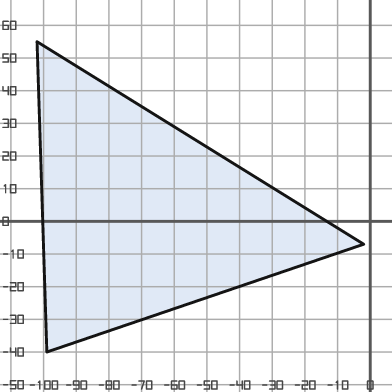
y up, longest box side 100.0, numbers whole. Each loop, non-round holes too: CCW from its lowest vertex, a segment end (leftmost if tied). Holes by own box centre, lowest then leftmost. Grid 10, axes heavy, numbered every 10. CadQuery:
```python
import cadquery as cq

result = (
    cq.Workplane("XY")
    .moveTo(-99.0, -40.0)
    .lineTo(-2.0, -7.0)
    .lineTo(-102.0, 55.0)
    .close()
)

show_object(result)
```